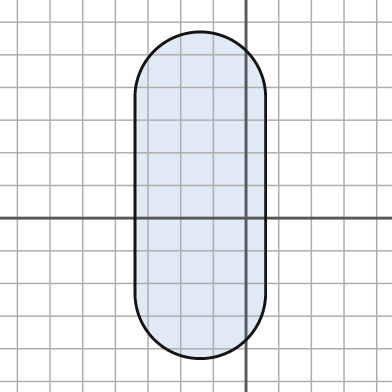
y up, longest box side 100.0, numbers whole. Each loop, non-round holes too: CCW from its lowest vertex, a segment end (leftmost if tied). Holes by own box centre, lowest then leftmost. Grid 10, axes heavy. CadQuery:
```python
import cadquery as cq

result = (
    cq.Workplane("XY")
    .moveTo(-34.0, -23.0)
    .threePointArc((-14.0, -43.0), (6.0, -23.0))
    .lineTo(6.0, 37.0)
    .threePointArc((-14.0, 57.0), (-34.0, 37.0))
    .close()
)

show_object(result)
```